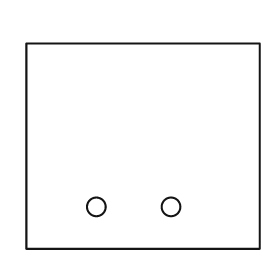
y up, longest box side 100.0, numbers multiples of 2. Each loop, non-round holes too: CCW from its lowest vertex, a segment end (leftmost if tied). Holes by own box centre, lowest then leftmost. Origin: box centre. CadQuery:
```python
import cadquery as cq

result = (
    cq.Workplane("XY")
    .moveTo(-50.0, -44.0)
    .lineTo(50.0, -44.0)
    .lineTo(50.0, 44.0)
    .lineTo(-50.0, 44.0)
    .close()
    .moveTo(-20.0, -26.0)
    .circle(4.0)
    .moveTo(12.0, -26.0)
    .circle(4.0)
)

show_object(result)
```